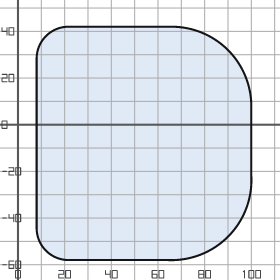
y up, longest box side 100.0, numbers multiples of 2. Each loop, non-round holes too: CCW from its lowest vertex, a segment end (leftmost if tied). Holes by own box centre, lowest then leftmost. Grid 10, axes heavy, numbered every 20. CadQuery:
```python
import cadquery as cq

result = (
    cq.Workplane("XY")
    .moveTo(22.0, -58.0)
    .lineTo(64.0, -58.0)
    .threePointArc((90.0, -48.0), (100.0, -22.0))
    .lineTo(100.0, 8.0)
    .threePointArc((90.0, 32.0), (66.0, 42.0))
    .lineTo(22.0, 42.0)
    .threePointArc((12.0, 38.0), (8.0, 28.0))
    .lineTo(8.0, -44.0)
    .threePointArc((12.0, -54.0), (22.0, -58.0))
    .close()
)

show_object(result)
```